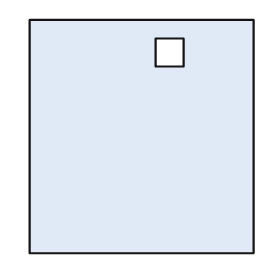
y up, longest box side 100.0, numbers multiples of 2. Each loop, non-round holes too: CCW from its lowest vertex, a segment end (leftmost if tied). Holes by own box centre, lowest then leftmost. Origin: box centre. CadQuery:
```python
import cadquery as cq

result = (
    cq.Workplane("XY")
    .moveTo(-48.0, -50.0)
    .lineTo(48.0, -50.0)
    .lineTo(48.0, 50.0)
    .lineTo(-48.0, 50.0)
    .close()
    .moveTo(6.0, 30.0)
    .lineTo(18.0, 30.0)
    .lineTo(18.0, 42.0)
    .lineTo(6.0, 42.0)
    .close()
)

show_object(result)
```